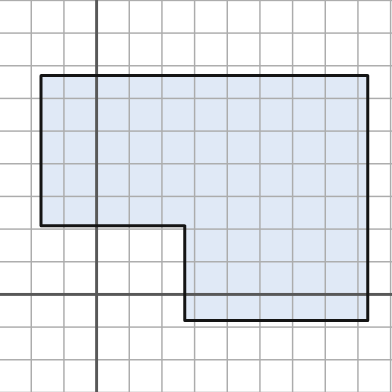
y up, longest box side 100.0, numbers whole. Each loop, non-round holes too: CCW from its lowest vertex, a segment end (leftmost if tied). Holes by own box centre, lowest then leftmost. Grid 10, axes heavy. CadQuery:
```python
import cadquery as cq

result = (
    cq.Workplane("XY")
    .moveTo(27.0, -8.0)
    .lineTo(83.0, -8.0)
    .lineTo(83.0, 67.0)
    .lineTo(-17.0, 67.0)
    .lineTo(-17.0, 21.0)
    .lineTo(27.0, 21.0)
    .close()
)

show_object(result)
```